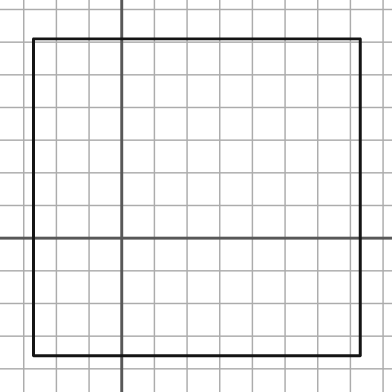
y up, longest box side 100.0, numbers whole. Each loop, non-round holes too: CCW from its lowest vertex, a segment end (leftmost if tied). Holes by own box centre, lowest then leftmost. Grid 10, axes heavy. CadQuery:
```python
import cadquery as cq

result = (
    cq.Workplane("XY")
    .moveTo(-27.0, -36.0)
    .lineTo(73.0, -36.0)
    .lineTo(73.0, 61.0)
    .lineTo(-27.0, 61.0)
    .close()
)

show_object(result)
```